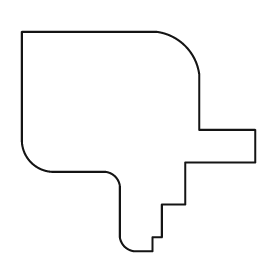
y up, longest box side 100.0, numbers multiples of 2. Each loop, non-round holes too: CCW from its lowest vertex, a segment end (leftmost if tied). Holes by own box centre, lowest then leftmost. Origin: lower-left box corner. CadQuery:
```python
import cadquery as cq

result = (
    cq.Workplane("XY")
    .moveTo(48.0, 0.0)
    .lineTo(56.0, 0.0)
    .lineTo(56.0, 6.0)
    .lineTo(60.0, 6.0)
    .lineTo(60.0, 20.0)
    .lineTo(70.0, 20.0)
    .lineTo(70.0, 38.0)
    .lineTo(100.0, 38.0)
    .lineTo(100.0, 52.0)
    .lineTo(76.0, 52.0)
    .lineTo(76.0, 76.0)
    .threePointArc((70.0, 88.0), (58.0, 94.0))
    .lineTo(0.0, 94.0)
    .lineTo(0.0, 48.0)
    .threePointArc((4.0, 38.0), (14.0, 34.0))
    .lineTo(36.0, 34.0)
    .threePointArc((40.0, 32.0), (42.0, 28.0))
    .lineTo(42.0, 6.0)
    .threePointArc((44.0, 2.0), (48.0, 0.0))
    .close()
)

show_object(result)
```